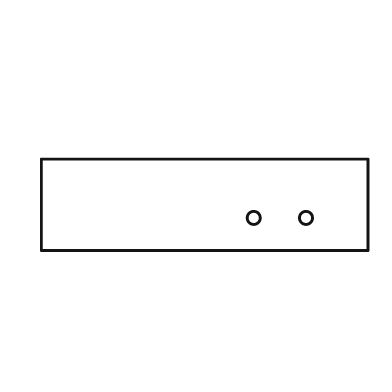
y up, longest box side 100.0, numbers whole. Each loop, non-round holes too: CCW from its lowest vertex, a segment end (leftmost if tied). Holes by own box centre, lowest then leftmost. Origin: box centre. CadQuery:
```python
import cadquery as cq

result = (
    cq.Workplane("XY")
    .moveTo(-50.0, -14.0)
    .lineTo(50.0, -14.0)
    .lineTo(50.0, 14.0)
    .lineTo(-50.0, 14.0)
    .close()
    .moveTo(15.0, -4.0)
    .circle(2.0)
    .moveTo(31.0, -4.0)
    .circle(2.0)
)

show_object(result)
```